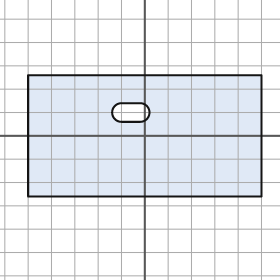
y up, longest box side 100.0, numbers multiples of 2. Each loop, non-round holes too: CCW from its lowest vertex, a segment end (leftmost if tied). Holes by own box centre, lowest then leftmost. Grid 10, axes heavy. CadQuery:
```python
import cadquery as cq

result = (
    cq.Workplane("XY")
    .moveTo(-50.0, -26.0)
    .lineTo(50.0, -26.0)
    .lineTo(50.0, 26.0)
    .lineTo(-50.0, 26.0)
    .close()
    .moveTo(-10.0, 6.0)
    .lineTo(-2.0, 6.0)
    .threePointArc((2.0, 10.0), (-2.0, 14.0))
    .lineTo(-10.0, 14.0)
    .threePointArc((-14.0, 10.0), (-10.0, 6.0))
    .close()
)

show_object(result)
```